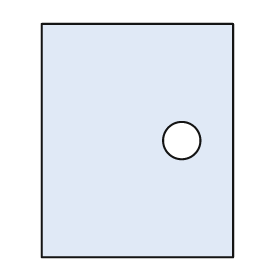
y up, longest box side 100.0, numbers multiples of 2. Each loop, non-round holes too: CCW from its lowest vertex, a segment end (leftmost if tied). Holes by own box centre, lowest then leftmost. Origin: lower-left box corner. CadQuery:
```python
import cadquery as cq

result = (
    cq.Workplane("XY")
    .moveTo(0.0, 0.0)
    .lineTo(82.0, 0.0)
    .lineTo(82.0, 100.0)
    .lineTo(0.0, 100.0)
    .close()
    .moveTo(60.0, 50.0)
    .circle(8.0)
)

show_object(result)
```